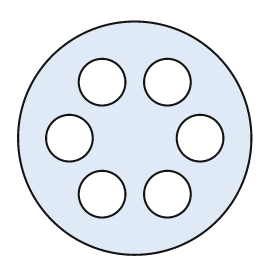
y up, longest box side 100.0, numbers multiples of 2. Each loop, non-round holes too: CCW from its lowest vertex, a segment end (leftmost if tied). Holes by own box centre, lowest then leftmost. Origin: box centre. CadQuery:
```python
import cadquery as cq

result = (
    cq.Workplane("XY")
    .moveTo(0.0, 0.0)
    .circle(50.0)
    .moveTo(-14.0, -24.0)
    .circle(10.0)
    .moveTo(14.0, -24.0)
    .circle(10.0)
    .moveTo(-28.0, 0.0)
    .circle(10.0)
    .moveTo(28.0, 0.0)
    .circle(10.0)
    .moveTo(-14.0, 24.0)
    .circle(10.0)
    .moveTo(14.0, 24.0)
    .circle(10.0)
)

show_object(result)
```